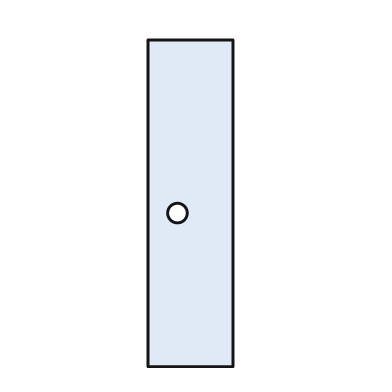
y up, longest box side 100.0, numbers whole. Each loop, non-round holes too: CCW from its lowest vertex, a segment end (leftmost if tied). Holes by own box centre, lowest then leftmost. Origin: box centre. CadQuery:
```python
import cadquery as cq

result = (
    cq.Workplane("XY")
    .moveTo(-13.0, -50.0)
    .lineTo(13.0, -50.0)
    .lineTo(13.0, 50.0)
    .lineTo(-13.0, 50.0)
    .close()
    .moveTo(-4.0, -3.0)
    .circle(3.0)
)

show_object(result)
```